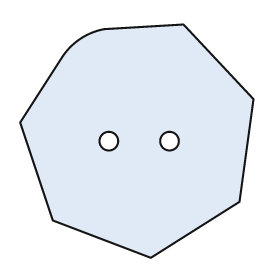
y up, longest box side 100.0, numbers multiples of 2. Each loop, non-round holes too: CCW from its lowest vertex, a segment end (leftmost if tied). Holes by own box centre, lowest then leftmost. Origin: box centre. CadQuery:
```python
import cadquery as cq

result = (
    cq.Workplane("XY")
    .moveTo(6.0, -50.0)
    .lineTo(44.0, -26.0)
    .lineTo(50.0, 18.0)
    .lineTo(20.0, 50.0)
    .lineTo(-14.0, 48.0)
    .threePointArc((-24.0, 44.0), (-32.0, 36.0))
    .lineTo(-50.0, 8.0)
    .lineTo(-36.0, -34.0)
    .close()
    .moveTo(-12.0, 0.0)
    .circle(4.0)
    .moveTo(14.0, 0.0)
    .circle(4.0)
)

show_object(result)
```